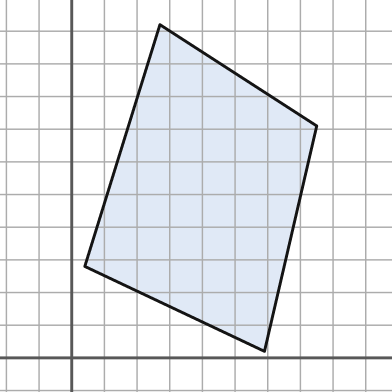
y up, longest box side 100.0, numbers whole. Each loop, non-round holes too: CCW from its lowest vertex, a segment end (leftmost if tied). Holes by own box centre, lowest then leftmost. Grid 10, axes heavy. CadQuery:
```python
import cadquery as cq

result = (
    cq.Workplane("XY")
    .moveTo(59.0, 2.0)
    .lineTo(75.0, 71.0)
    .lineTo(27.0, 102.0)
    .lineTo(4.0, 28.0)
    .close()
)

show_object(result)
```